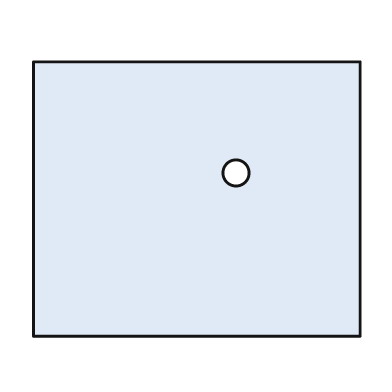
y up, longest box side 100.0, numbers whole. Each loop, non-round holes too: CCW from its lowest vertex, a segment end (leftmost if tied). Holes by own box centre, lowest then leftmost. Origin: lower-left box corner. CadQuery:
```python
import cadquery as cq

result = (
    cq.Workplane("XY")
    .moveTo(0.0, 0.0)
    .lineTo(100.0, 0.0)
    .lineTo(100.0, 84.0)
    .lineTo(0.0, 84.0)
    .close()
    .moveTo(62.0, 50.0)
    .circle(4.0)
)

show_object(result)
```